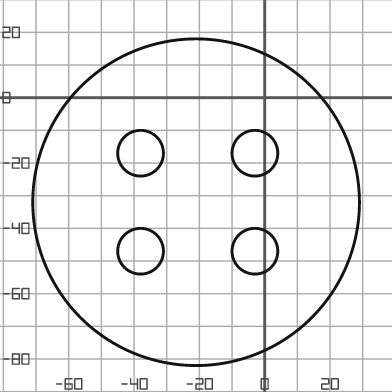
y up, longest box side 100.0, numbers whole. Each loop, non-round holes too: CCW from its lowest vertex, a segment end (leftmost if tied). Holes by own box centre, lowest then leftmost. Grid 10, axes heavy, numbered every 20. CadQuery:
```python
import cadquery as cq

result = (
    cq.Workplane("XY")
    .moveTo(-21.0, -32.0)
    .circle(50.0)
    .moveTo(-38.0, -47.0)
    .circle(7.0)
    .moveTo(-3.0, -47.0)
    .circle(7.0)
    .moveTo(-38.0, -17.0)
    .circle(7.0)
    .moveTo(-3.0, -17.0)
    .circle(7.0)
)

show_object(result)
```